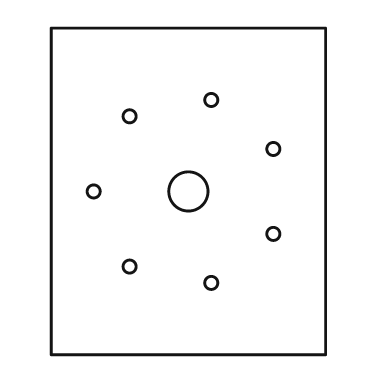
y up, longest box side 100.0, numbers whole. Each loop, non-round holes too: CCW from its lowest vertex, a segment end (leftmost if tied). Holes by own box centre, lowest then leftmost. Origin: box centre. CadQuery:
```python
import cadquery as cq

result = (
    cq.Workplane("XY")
    .moveTo(-42.0, -50.0)
    .lineTo(42.0, -50.0)
    .lineTo(42.0, 50.0)
    .lineTo(-42.0, 50.0)
    .close()
    .moveTo(7.0, -28.0)
    .circle(2.0)
    .moveTo(-18.0, -23.0)
    .circle(2.0)
    .moveTo(26.0, -13.0)
    .circle(2.0)
    .moveTo(-29.0, 0.0)
    .circle(2.0)
    .moveTo(0.0, 0.0)
    .circle(6.0)
    .moveTo(26.0, 13.0)
    .circle(2.0)
    .moveTo(-18.0, 23.0)
    .circle(2.0)
    .moveTo(7.0, 28.0)
    .circle(2.0)
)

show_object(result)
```